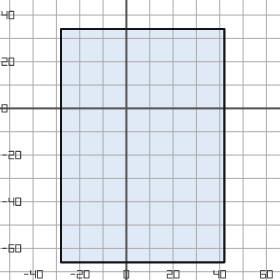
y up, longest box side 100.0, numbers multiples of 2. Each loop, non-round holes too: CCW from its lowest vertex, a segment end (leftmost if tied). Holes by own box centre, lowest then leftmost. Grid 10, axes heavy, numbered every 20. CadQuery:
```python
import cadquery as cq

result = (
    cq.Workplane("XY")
    .moveTo(-28.0, -66.0)
    .lineTo(42.0, -66.0)
    .lineTo(42.0, 34.0)
    .lineTo(-28.0, 34.0)
    .close()
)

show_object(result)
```